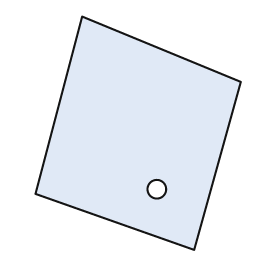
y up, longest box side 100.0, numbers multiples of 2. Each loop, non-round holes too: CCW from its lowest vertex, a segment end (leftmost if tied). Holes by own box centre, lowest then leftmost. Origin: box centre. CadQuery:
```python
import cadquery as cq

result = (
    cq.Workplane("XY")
    .moveTo(24.0, -50.0)
    .lineTo(44.0, 22.0)
    .lineTo(-24.0, 50.0)
    .lineTo(-44.0, -26.0)
    .close()
    .moveTo(8.0, -24.0)
    .circle(4.0)
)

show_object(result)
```